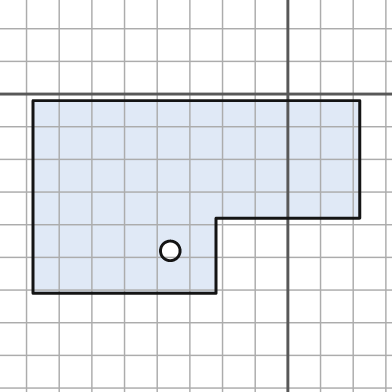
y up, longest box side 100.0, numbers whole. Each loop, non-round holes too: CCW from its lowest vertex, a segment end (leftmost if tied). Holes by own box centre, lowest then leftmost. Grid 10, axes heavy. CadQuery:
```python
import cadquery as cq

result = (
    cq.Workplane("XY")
    .moveTo(-78.0, -61.0)
    .lineTo(-22.0, -61.0)
    .lineTo(-22.0, -38.0)
    .lineTo(22.0, -38.0)
    .lineTo(22.0, -2.0)
    .lineTo(-78.0, -2.0)
    .close()
    .moveTo(-36.0, -48.0)
    .circle(3.0)
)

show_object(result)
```